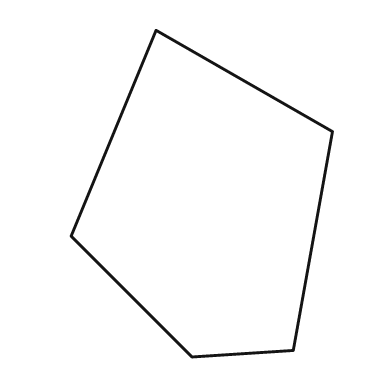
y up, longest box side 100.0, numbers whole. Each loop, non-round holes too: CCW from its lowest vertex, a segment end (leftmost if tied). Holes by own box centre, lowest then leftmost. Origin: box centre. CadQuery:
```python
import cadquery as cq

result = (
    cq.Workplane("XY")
    .moveTo(-3.0, -50.0)
    .lineTo(28.0, -48.0)
    .lineTo(40.0, 19.0)
    .lineTo(-14.0, 50.0)
    .lineTo(-40.0, -13.0)
    .close()
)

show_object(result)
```